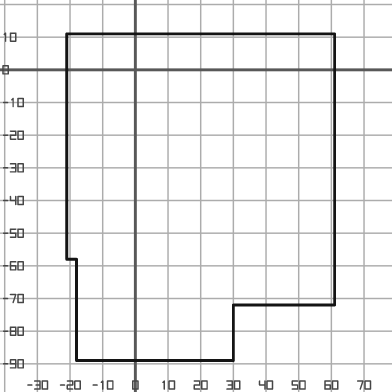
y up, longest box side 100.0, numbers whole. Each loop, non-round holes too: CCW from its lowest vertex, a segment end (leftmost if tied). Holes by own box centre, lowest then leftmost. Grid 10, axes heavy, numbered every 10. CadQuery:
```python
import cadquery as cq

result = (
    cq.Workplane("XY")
    .moveTo(-18.0, -89.0)
    .lineTo(30.0, -89.0)
    .lineTo(30.0, -72.0)
    .lineTo(61.0, -72.0)
    .lineTo(61.0, 11.0)
    .lineTo(-21.0, 11.0)
    .lineTo(-21.0, -58.0)
    .lineTo(-18.0, -58.0)
    .close()
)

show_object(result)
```